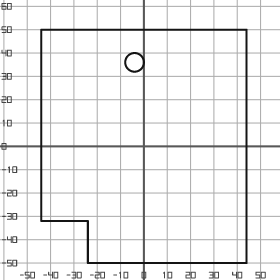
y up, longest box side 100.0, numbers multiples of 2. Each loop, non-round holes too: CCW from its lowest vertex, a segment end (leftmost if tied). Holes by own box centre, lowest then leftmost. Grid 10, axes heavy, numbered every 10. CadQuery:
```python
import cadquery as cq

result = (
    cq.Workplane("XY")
    .moveTo(-24.0, -50.0)
    .lineTo(44.0, -50.0)
    .lineTo(44.0, 50.0)
    .lineTo(-44.0, 50.0)
    .lineTo(-44.0, -32.0)
    .lineTo(-24.0, -32.0)
    .close()
    .moveTo(-4.0, 36.0)
    .circle(4.0)
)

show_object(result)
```